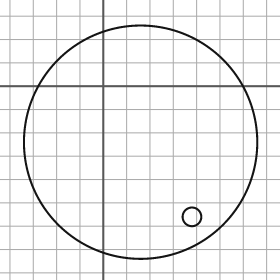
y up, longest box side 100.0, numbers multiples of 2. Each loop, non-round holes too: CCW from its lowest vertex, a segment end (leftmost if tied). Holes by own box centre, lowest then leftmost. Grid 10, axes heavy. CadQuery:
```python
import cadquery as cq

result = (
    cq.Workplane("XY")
    .moveTo(16.0, -24.0)
    .circle(50.0)
    .moveTo(38.0, -56.0)
    .circle(4.0)
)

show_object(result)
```